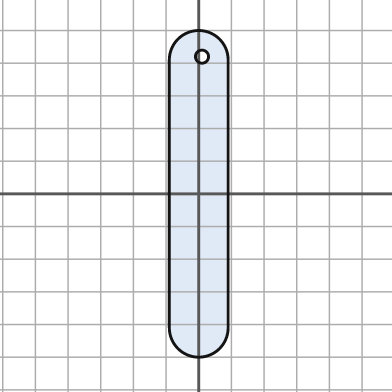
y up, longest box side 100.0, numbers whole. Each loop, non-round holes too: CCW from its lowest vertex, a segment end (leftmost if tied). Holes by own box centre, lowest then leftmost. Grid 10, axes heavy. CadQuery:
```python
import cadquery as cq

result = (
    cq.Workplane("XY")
    .moveTo(-9.0, -41.0)
    .threePointArc((0.0, -50.0), (9.0, -41.0))
    .lineTo(9.0, 41.0)
    .threePointArc((0.0, 50.0), (-9.0, 41.0))
    .close()
    .moveTo(1.0, 42.0)
    .circle(2.0)
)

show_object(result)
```